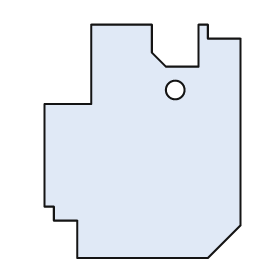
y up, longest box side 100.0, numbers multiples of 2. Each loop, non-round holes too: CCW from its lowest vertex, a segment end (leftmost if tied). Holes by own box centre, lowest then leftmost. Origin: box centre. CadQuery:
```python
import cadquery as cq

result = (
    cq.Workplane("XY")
    .moveTo(-28.0, -50.0)
    .lineTo(28.0, -50.0)
    .lineTo(42.0, -36.0)
    .lineTo(42.0, 44.0)
    .lineTo(28.0, 44.0)
    .lineTo(28.0, 50.0)
    .lineTo(24.0, 50.0)
    .lineTo(24.0, 32.0)
    .lineTo(10.0, 32.0)
    .lineTo(4.0, 38.0)
    .lineTo(4.0, 50.0)
    .lineTo(-22.0, 50.0)
    .lineTo(-22.0, 16.0)
    .lineTo(-42.0, 16.0)
    .lineTo(-42.0, -28.0)
    .lineTo(-38.0, -28.0)
    .lineTo(-38.0, -34.0)
    .lineTo(-28.0, -34.0)
    .close()
    .moveTo(14.0, 22.0)
    .circle(4.0)
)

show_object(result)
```